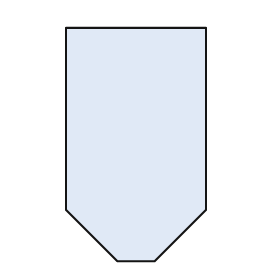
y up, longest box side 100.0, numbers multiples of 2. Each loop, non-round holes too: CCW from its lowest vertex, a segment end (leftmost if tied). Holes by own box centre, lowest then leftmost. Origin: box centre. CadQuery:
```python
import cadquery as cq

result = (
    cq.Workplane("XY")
    .moveTo(-8.0, -50.0)
    .lineTo(8.0, -50.0)
    .lineTo(30.0, -28.0)
    .lineTo(30.0, 50.0)
    .lineTo(-30.0, 50.0)
    .lineTo(-30.0, -28.0)
    .close()
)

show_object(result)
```